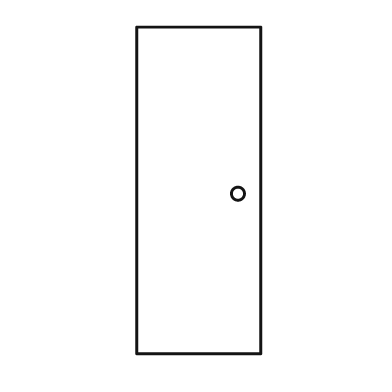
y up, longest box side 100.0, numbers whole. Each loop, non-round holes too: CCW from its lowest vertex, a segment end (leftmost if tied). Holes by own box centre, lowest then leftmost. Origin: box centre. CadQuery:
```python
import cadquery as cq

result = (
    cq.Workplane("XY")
    .moveTo(-19.0, -50.0)
    .lineTo(19.0, -50.0)
    .lineTo(19.0, 50.0)
    .lineTo(-19.0, 50.0)
    .close()
    .moveTo(12.0, -1.0)
    .circle(2.0)
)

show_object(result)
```